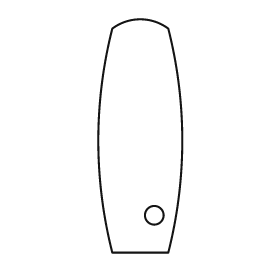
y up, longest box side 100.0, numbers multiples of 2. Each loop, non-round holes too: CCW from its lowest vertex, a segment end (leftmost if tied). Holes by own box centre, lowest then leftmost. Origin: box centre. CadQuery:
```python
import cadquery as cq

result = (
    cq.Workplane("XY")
    .moveTo(-12.0, -50.0)
    .lineTo(12.0, -50.0)
    .threePointArc((18.0, -2.0), (12.0, 46.0))
    .threePointArc((0.0, 50.0), (-12.0, 46.0))
    .threePointArc((-18.0, -2.0), (-12.0, -50.0))
    .close()
    .moveTo(6.0, -34.0)
    .circle(4.0)
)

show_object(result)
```